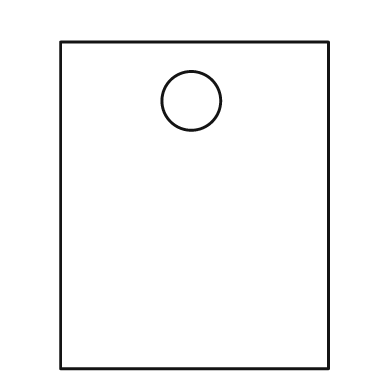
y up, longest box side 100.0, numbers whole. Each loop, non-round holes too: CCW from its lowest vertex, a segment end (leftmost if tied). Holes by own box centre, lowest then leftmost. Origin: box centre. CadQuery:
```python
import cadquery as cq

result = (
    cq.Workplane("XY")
    .moveTo(-41.0, -50.0)
    .lineTo(41.0, -50.0)
    .lineTo(41.0, 50.0)
    .lineTo(-41.0, 50.0)
    .close()
    .moveTo(-1.0, 32.0)
    .circle(9.0)
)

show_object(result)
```